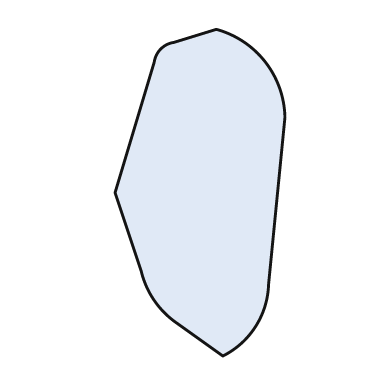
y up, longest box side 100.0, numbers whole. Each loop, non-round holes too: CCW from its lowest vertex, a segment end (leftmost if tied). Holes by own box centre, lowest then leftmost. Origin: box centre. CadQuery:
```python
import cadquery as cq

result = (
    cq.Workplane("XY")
    .moveTo(7.0, -50.0)
    .threePointArc((17.0, -41.0), (21.0, -28.0))
    .lineTo(26.0, 23.0)
    .threePointArc((20.0, 40.0), (5.0, 50.0))
    .lineTo(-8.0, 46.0)
    .threePointArc((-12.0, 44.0), (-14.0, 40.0))
    .lineTo(-26.0, 0.0)
    .lineTo(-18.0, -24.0)
    .threePointArc((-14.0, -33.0), (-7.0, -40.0))
    .close()
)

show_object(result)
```